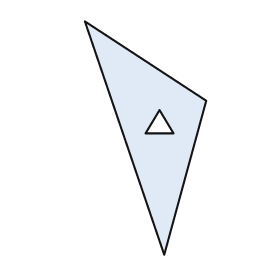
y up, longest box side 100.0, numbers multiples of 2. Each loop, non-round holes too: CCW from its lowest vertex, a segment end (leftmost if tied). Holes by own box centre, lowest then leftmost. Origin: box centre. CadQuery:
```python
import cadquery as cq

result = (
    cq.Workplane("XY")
    .moveTo(8.0, -50.0)
    .lineTo(26.0, 16.0)
    .lineTo(-26.0, 50.0)
    .close()
    .moveTo(0.0, 2.0)
    .lineTo(12.0, 2.0)
    .lineTo(6.0, 12.0)
    .close()
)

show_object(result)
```